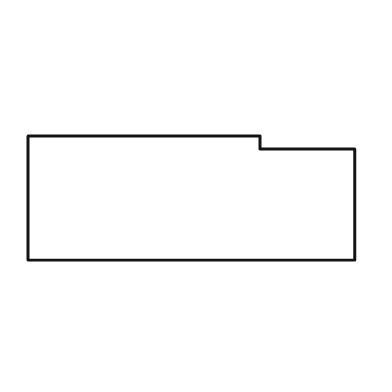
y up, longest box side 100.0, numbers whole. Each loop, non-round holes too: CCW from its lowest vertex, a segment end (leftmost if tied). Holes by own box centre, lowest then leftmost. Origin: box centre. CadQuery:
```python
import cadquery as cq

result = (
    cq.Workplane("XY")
    .moveTo(-50.0, -19.0)
    .lineTo(50.0, -19.0)
    .lineTo(50.0, 15.0)
    .lineTo(21.0, 15.0)
    .lineTo(21.0, 19.0)
    .lineTo(-50.0, 19.0)
    .close()
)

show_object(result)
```